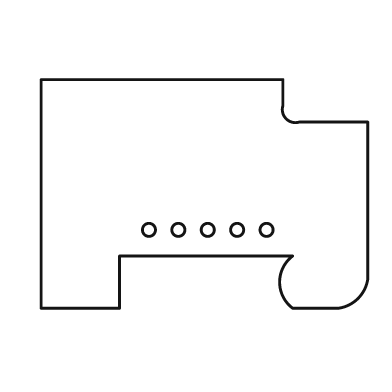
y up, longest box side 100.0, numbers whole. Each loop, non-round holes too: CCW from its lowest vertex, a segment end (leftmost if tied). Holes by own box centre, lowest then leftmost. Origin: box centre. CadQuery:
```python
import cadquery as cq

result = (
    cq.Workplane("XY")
    .moveTo(-50.0, -35.0)
    .lineTo(-26.0, -35.0)
    .lineTo(-26.0, -19.0)
    .lineTo(27.0, -19.0)
    .threePointArc((23.0, -27.0), (27.0, -35.0))
    .lineTo(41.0, -35.0)
    .threePointArc((47.0, -32.0), (50.0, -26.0))
    .lineTo(50.0, 22.0)
    .lineTo(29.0, 22.0)
    .threePointArc((25.0, 23.0), (24.0, 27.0))
    .lineTo(24.0, 35.0)
    .lineTo(-50.0, 35.0)
    .close()
    .moveTo(-17.0, -11.0)
    .circle(2.0)
    .moveTo(-8.0, -11.0)
    .circle(2.0)
    .moveTo(1.0, -11.0)
    .circle(2.0)
    .moveTo(10.0, -11.0)
    .circle(2.0)
    .moveTo(19.0, -11.0)
    .circle(2.0)
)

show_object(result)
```